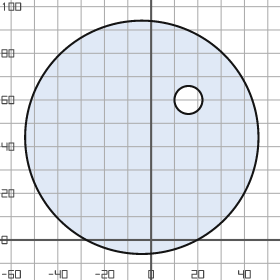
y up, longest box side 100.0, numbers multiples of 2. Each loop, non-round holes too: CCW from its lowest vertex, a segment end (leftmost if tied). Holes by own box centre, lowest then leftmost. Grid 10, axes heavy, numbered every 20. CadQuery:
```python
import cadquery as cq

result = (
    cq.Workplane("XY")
    .moveTo(-4.0, 44.0)
    .circle(50.0)
    .moveTo(16.0, 60.0)
    .circle(6.0)
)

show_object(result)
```